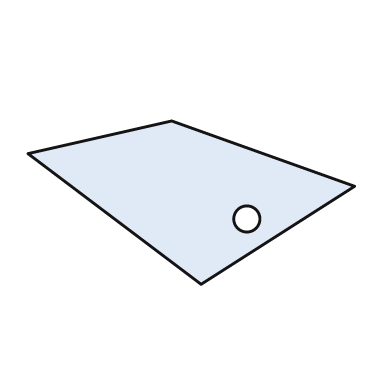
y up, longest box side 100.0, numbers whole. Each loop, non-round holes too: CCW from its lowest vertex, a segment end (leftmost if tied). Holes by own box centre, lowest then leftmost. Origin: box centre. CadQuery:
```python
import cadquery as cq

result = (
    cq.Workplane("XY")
    .moveTo(3.0, -25.0)
    .lineTo(50.0, 5.0)
    .lineTo(-6.0, 25.0)
    .lineTo(-50.0, 15.0)
    .close()
    .moveTo(17.0, -5.0)
    .circle(4.0)
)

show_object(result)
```